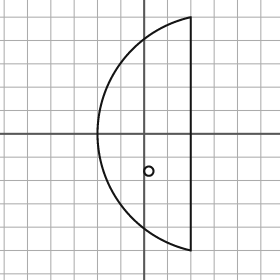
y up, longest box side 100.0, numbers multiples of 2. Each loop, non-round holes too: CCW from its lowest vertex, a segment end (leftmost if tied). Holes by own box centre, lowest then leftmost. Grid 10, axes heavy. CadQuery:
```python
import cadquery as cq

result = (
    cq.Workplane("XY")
    .moveTo(20.0, -50.0)
    .lineTo(20.0, 50.0)
    .threePointArc((-20.0, 0.0), (20.0, -50.0))
    .close()
    .moveTo(2.0, -16.0)
    .circle(2.0)
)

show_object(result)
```